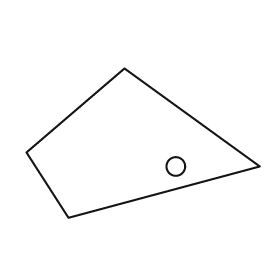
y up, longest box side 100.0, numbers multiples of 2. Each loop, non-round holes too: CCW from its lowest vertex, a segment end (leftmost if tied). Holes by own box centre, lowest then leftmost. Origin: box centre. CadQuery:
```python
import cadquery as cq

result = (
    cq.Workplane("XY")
    .moveTo(-32.0, -32.0)
    .lineTo(50.0, -10.0)
    .lineTo(-8.0, 32.0)
    .lineTo(-50.0, -4.0)
    .close()
    .moveTo(14.0, -10.0)
    .circle(4.0)
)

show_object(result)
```